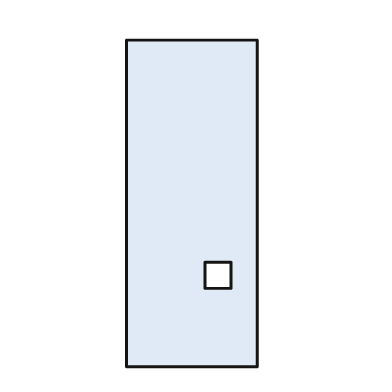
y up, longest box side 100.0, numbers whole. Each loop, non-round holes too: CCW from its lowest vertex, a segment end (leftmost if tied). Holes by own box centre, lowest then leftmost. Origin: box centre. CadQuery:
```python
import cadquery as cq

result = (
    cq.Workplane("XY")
    .moveTo(-20.0, -50.0)
    .lineTo(20.0, -50.0)
    .lineTo(20.0, 50.0)
    .lineTo(-20.0, 50.0)
    .close()
    .moveTo(4.0, -26.0)
    .lineTo(12.0, -26.0)
    .lineTo(12.0, -18.0)
    .lineTo(4.0, -18.0)
    .close()
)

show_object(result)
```